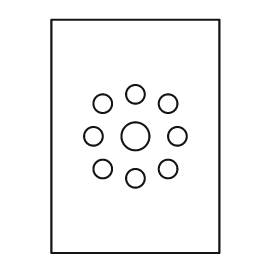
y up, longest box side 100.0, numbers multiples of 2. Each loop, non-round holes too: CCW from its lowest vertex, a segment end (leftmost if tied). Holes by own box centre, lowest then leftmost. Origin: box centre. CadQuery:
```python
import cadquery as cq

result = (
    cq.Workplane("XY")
    .moveTo(-36.0, -50.0)
    .lineTo(36.0, -50.0)
    .lineTo(36.0, 50.0)
    .lineTo(-36.0, 50.0)
    .close()
    .moveTo(0.0, -18.0)
    .circle(4.0)
    .moveTo(-14.0, -14.0)
    .circle(4.0)
    .moveTo(14.0, -14.0)
    .circle(4.0)
    .moveTo(-18.0, 0.0)
    .circle(4.0)
    .moveTo(0.0, 0.0)
    .circle(6.0)
    .moveTo(18.0, 0.0)
    .circle(4.0)
    .moveTo(-14.0, 14.0)
    .circle(4.0)
    .moveTo(14.0, 14.0)
    .circle(4.0)
    .moveTo(0.0, 18.0)
    .circle(4.0)
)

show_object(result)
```